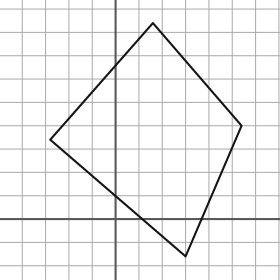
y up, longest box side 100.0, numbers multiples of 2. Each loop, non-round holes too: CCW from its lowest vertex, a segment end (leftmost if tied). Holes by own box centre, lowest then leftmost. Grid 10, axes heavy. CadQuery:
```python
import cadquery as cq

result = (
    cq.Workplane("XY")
    .moveTo(30.0, -16.0)
    .lineTo(54.0, 40.0)
    .lineTo(16.0, 84.0)
    .lineTo(-28.0, 34.0)
    .close()
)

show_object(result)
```